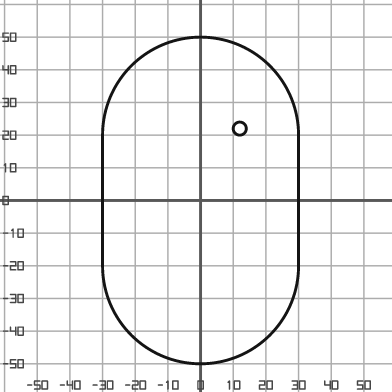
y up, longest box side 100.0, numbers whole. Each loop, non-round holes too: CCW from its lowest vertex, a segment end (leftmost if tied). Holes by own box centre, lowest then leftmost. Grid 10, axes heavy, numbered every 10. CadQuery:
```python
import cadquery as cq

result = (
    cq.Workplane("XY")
    .moveTo(-30.0, -20.0)
    .threePointArc((0.0, -50.0), (30.0, -20.0))
    .lineTo(30.0, 20.0)
    .threePointArc((0.0, 50.0), (-30.0, 20.0))
    .close()
    .moveTo(12.0, 22.0)
    .circle(2.0)
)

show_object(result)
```